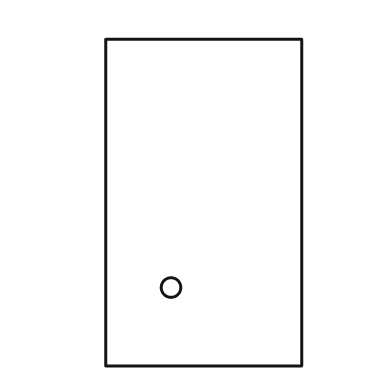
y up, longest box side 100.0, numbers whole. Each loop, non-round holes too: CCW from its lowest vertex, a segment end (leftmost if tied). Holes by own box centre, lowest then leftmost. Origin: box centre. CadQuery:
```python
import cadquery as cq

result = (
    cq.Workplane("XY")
    .moveTo(-30.0, -50.0)
    .lineTo(30.0, -50.0)
    .lineTo(30.0, 50.0)
    .lineTo(-30.0, 50.0)
    .close()
    .moveTo(-10.0, -26.0)
    .circle(3.0)
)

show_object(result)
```